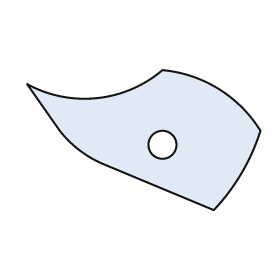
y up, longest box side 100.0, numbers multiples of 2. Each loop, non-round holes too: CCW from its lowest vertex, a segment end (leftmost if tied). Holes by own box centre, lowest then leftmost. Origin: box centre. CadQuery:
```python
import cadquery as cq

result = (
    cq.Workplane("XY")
    .moveTo(30.0, -30.0)
    .threePointArc((42.0, -14.0), (50.0, 4.0))
    .threePointArc((32.0, 22.0), (8.0, 30.0))
    .threePointArc((-20.0, 18.0), (-50.0, 24.0))
    .lineTo(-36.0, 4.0)
    .threePointArc((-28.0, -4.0), (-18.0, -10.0))
    .close()
    .moveTo(8.0, -2.0)
    .circle(6.0)
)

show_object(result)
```